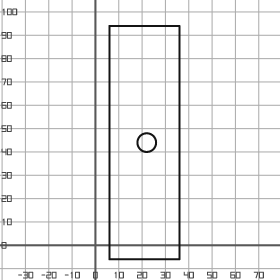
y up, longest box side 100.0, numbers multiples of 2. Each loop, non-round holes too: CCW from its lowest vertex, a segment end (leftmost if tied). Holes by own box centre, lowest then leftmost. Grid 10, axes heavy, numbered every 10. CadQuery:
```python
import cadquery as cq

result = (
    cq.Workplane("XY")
    .moveTo(6.0, -6.0)
    .lineTo(36.0, -6.0)
    .lineTo(36.0, 94.0)
    .lineTo(6.0, 94.0)
    .close()
    .moveTo(22.0, 44.0)
    .circle(4.0)
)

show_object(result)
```